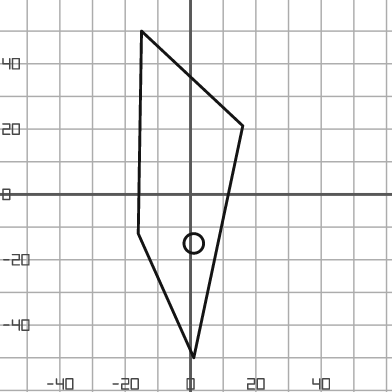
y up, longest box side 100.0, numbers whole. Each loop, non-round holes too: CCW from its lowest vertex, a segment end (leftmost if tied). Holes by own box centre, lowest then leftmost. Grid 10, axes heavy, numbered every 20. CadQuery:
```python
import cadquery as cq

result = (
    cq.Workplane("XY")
    .moveTo(1.0, -50.0)
    .lineTo(16.0, 21.0)
    .lineTo(-15.0, 50.0)
    .lineTo(-16.0, -12.0)
    .close()
    .moveTo(1.0, -15.0)
    .circle(3.0)
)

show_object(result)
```